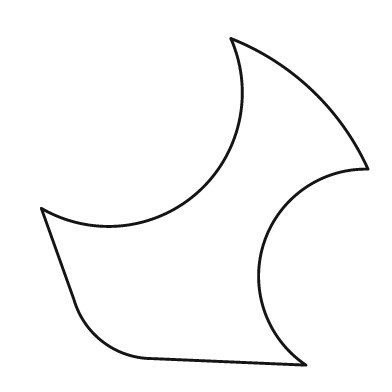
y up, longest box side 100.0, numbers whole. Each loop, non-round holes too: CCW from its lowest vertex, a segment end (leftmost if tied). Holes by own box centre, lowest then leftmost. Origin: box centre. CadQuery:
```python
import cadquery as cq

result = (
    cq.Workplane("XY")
    .moveTo(31.0, -50.0)
    .threePointArc((18.0, -13.0), (50.0, 10.0))
    .threePointArc((33.0, 34.0), (8.0, 50.0))
    .threePointArc((-2.0, 3.0), (-50.0, -2.0))
    .lineTo(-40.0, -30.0)
    .threePointArc((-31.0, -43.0), (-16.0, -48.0))
    .close()
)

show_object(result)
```